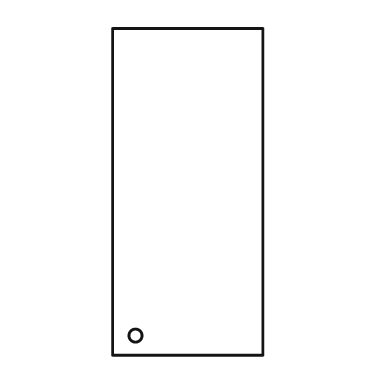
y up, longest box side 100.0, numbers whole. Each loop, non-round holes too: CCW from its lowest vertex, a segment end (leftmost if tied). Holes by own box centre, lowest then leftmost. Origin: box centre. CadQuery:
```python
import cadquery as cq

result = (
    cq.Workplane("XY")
    .moveTo(-23.0, -50.0)
    .lineTo(23.0, -50.0)
    .lineTo(23.0, 50.0)
    .lineTo(-23.0, 50.0)
    .close()
    .moveTo(-16.0, -44.0)
    .circle(2.0)
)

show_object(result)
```